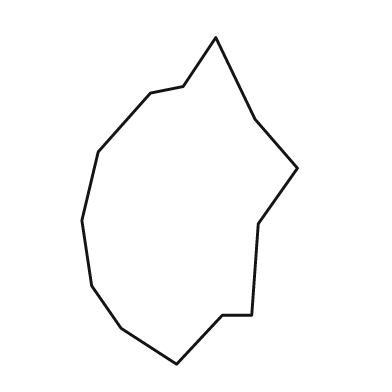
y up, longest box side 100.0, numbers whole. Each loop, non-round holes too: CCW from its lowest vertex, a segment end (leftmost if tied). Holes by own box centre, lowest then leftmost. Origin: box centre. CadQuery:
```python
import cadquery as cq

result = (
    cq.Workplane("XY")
    .moveTo(-4.0, -50.0)
    .lineTo(10.0, -35.0)
    .lineTo(19.0, -35.0)
    .lineTo(21.0, -7.0)
    .lineTo(33.0, 10.0)
    .lineTo(20.0, 25.0)
    .lineTo(8.0, 50.0)
    .lineTo(-2.0, 35.0)
    .lineTo(-12.0, 33.0)
    .lineTo(-28.0, 15.0)
    .lineTo(-33.0, -6.0)
    .lineTo(-30.0, -26.0)
    .lineTo(-21.0, -39.0)
    .close()
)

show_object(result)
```